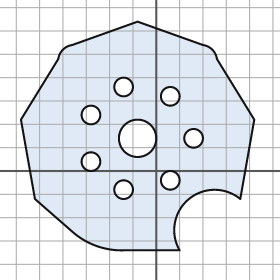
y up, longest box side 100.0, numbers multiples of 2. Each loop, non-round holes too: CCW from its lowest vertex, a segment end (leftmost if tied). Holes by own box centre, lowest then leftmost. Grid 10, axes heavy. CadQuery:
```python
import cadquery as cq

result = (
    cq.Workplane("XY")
    .moveTo(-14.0, -34.0)
    .lineTo(10.0, -34.0)
    .threePointArc((14.0, -12.0), (36.0, -12.0))
    .lineTo(42.0, 22.0)
    .lineTo(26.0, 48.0)
    .threePointArc((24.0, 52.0), (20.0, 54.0))
    .lineTo(-8.0, 64.0)
    .lineTo(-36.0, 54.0)
    .threePointArc((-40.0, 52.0), (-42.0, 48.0))
    .lineTo(-58.0, 22.0)
    .lineTo(-52.0, -12.0)
    .lineTo(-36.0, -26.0)
    .threePointArc((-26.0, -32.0), (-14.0, -34.0))
    .close()
    .moveTo(-14.0, -8.0)
    .circle(4.0)
    .moveTo(6.0, -4.0)
    .circle(4.0)
    .moveTo(-28.0, 4.0)
    .circle(4.0)
    .moveTo(-8.0, 14.0)
    .circle(8.0)
    .moveTo(16.0, 14.0)
    .circle(4.0)
    .moveTo(-28.0, 24.0)
    .circle(4.0)
    .moveTo(6.0, 32.0)
    .circle(4.0)
    .moveTo(-14.0, 36.0)
    .circle(4.0)
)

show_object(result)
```